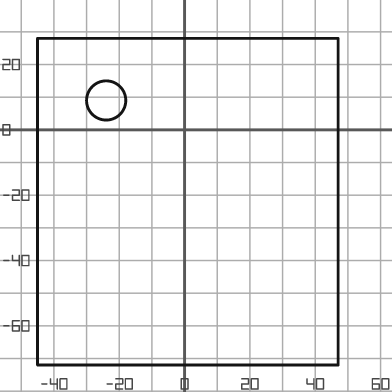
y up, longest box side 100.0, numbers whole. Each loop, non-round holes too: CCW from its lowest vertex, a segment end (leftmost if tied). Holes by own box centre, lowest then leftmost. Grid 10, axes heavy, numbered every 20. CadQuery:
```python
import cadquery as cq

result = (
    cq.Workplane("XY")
    .moveTo(-45.0, -72.0)
    .lineTo(47.0, -72.0)
    .lineTo(47.0, 28.0)
    .lineTo(-45.0, 28.0)
    .close()
    .moveTo(-24.0, 9.0)
    .circle(6.0)
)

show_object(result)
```